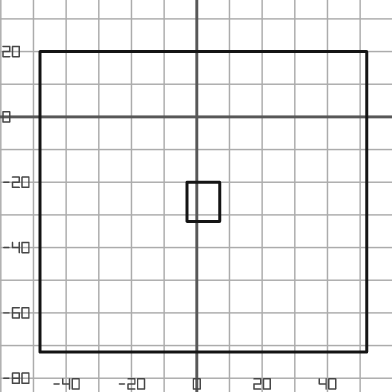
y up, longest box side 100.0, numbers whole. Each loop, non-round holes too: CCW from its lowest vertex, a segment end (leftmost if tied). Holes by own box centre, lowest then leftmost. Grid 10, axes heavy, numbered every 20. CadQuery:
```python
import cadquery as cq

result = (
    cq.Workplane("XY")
    .moveTo(-48.0, -72.0)
    .lineTo(52.0, -72.0)
    .lineTo(52.0, 20.0)
    .lineTo(-48.0, 20.0)
    .close()
    .moveTo(-3.0, -32.0)
    .lineTo(7.0, -32.0)
    .lineTo(7.0, -20.0)
    .lineTo(-3.0, -20.0)
    .close()
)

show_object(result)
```